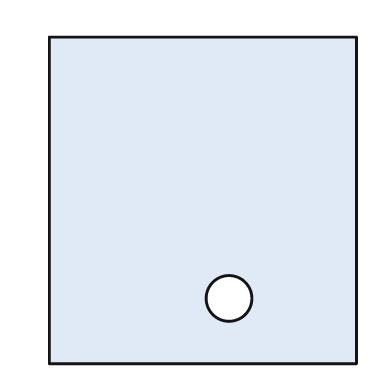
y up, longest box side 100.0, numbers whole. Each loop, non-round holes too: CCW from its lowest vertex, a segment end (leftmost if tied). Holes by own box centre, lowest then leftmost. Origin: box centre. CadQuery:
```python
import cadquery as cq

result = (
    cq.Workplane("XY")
    .moveTo(-47.0, -50.0)
    .lineTo(47.0, -50.0)
    .lineTo(47.0, 50.0)
    .lineTo(-47.0, 50.0)
    .close()
    .moveTo(8.0, -30.0)
    .circle(7.0)
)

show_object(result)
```